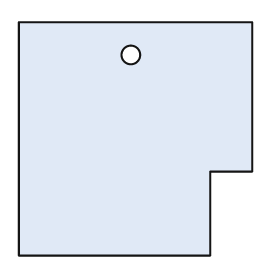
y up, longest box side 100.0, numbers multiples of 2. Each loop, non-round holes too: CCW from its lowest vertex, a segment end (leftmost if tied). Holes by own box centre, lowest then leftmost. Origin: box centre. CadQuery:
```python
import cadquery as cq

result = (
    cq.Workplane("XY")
    .moveTo(-50.0, -50.0)
    .lineTo(32.0, -50.0)
    .lineTo(32.0, -14.0)
    .lineTo(50.0, -14.0)
    .lineTo(50.0, 50.0)
    .lineTo(-50.0, 50.0)
    .close()
    .moveTo(-2.0, 36.0)
    .circle(4.0)
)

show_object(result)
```